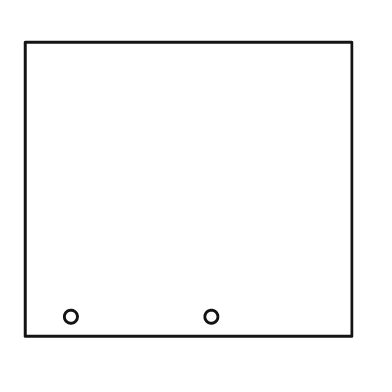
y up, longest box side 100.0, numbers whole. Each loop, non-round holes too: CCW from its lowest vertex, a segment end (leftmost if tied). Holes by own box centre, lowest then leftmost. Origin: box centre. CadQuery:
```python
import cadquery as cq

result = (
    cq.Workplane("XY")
    .moveTo(-50.0, -45.0)
    .lineTo(50.0, -45.0)
    .lineTo(50.0, 45.0)
    .lineTo(-50.0, 45.0)
    .close()
    .moveTo(-36.0, -39.0)
    .circle(2.0)
    .moveTo(7.0, -39.0)
    .circle(2.0)
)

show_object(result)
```